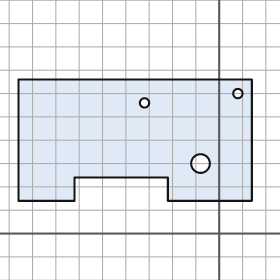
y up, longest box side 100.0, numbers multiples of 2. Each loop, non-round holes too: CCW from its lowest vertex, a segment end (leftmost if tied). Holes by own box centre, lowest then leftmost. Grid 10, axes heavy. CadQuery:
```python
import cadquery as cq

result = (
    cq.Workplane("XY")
    .moveTo(-86.0, 14.0)
    .lineTo(-62.0, 14.0)
    .lineTo(-62.0, 24.0)
    .lineTo(-22.0, 24.0)
    .lineTo(-22.0, 14.0)
    .lineTo(14.0, 14.0)
    .lineTo(14.0, 66.0)
    .lineTo(-86.0, 66.0)
    .close()
    .moveTo(-8.0, 30.0)
    .circle(4.0)
    .moveTo(-32.0, 56.0)
    .circle(2.0)
    .moveTo(8.0, 60.0)
    .circle(2.0)
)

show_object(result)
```